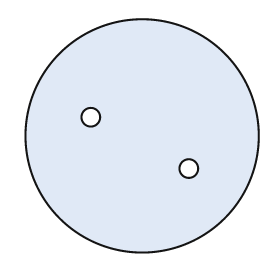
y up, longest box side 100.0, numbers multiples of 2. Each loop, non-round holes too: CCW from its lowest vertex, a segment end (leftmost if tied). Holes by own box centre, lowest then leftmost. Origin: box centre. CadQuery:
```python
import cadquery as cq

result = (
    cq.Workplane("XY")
    .moveTo(0.0, 0.0)
    .circle(50.0)
    .moveTo(20.0, -14.0)
    .circle(4.0)
    .moveTo(-22.0, 8.0)
    .circle(4.0)
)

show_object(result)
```